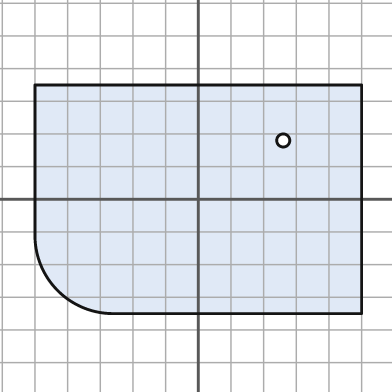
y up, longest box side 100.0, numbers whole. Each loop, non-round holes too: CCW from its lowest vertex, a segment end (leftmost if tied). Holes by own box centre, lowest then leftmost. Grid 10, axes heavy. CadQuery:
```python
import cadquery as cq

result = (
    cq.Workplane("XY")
    .moveTo(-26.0, -35.0)
    .lineTo(50.0, -35.0)
    .lineTo(50.0, 35.0)
    .lineTo(-50.0, 35.0)
    .lineTo(-50.0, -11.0)
    .threePointArc((-43.0, -28.0), (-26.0, -35.0))
    .close()
    .moveTo(26.0, 18.0)
    .circle(2.0)
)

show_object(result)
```